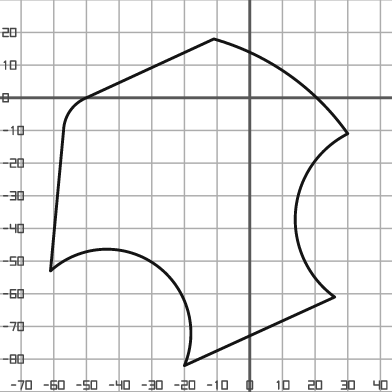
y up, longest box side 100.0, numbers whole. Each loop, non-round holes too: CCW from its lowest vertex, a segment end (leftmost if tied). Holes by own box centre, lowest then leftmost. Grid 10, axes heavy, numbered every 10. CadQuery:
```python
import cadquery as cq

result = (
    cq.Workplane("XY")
    .moveTo(-20.0, -82.0)
    .lineTo(26.0, -61.0)
    .threePointArc((14.0, -35.0), (30.0, -11.0))
    .threePointArc((12.0, 7.0), (-11.0, 18.0))
    .lineTo(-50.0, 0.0)
    .threePointArc((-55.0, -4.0), (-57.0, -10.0))
    .lineTo(-61.0, -53.0)
    .threePointArc((-29.0, -51.0), (-20.0, -82.0))
    .close()
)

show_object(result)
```